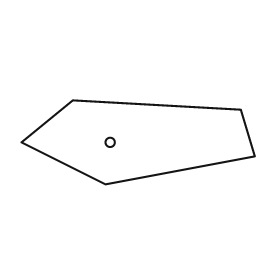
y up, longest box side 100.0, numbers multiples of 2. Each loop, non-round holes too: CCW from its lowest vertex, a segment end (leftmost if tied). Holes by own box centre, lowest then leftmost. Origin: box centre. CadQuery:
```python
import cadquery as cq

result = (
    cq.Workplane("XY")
    .moveTo(-14.0, -18.0)
    .lineTo(50.0, -6.0)
    .lineTo(44.0, 14.0)
    .lineTo(-28.0, 18.0)
    .lineTo(-50.0, 0.0)
    .close()
    .moveTo(-12.0, 0.0)
    .circle(2.0)
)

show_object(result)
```